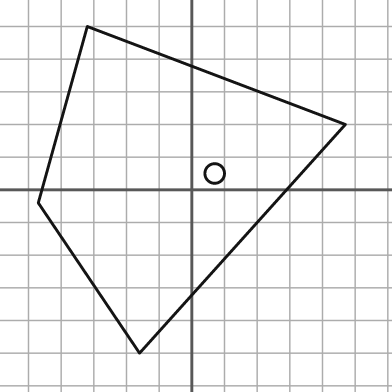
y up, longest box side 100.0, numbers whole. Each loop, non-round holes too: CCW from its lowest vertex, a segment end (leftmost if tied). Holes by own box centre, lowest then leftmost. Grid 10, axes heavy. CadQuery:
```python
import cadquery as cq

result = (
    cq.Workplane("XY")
    .moveTo(-16.0, -50.0)
    .lineTo(47.0, 20.0)
    .lineTo(-32.0, 50.0)
    .lineTo(-47.0, -4.0)
    .close()
    .moveTo(7.0, 5.0)
    .circle(3.0)
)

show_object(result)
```